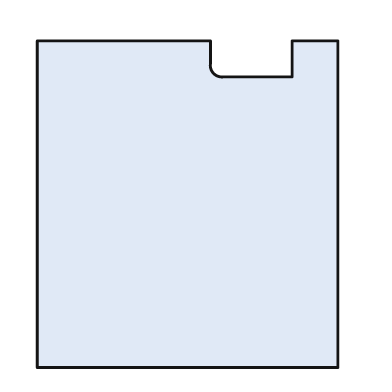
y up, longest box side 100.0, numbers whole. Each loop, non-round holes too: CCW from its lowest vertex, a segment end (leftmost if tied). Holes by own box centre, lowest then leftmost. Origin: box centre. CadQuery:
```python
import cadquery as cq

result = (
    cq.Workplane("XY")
    .moveTo(-46.0, -50.0)
    .lineTo(46.0, -50.0)
    .lineTo(46.0, 50.0)
    .lineTo(32.0, 50.0)
    .lineTo(32.0, 39.0)
    .lineTo(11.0, 39.0)
    .threePointArc((8.0, 40.0), (7.0, 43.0))
    .lineTo(7.0, 50.0)
    .lineTo(-46.0, 50.0)
    .close()
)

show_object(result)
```